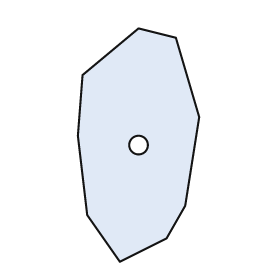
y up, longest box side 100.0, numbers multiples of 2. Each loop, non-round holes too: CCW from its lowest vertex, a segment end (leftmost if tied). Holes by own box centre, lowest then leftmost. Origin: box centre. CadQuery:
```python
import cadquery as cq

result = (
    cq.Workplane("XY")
    .moveTo(-8.0, -50.0)
    .lineTo(12.0, -40.0)
    .lineTo(20.0, -26.0)
    .lineTo(26.0, 12.0)
    .lineTo(16.0, 46.0)
    .lineTo(0.0, 50.0)
    .lineTo(-24.0, 30.0)
    .lineTo(-26.0, 4.0)
    .lineTo(-22.0, -30.0)
    .close()
    .moveTo(0.0, 0.0)
    .circle(4.0)
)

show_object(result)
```